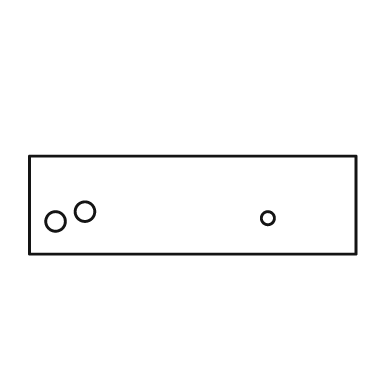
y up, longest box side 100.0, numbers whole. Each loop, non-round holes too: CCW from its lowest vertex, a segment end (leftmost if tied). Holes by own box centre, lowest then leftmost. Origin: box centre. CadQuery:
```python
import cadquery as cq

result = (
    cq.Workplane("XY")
    .moveTo(-50.0, -15.0)
    .lineTo(50.0, -15.0)
    .lineTo(50.0, 15.0)
    .lineTo(-50.0, 15.0)
    .close()
    .moveTo(-42.0, -5.0)
    .circle(3.0)
    .moveTo(23.0, -4.0)
    .circle(2.0)
    .moveTo(-33.0, -2.0)
    .circle(3.0)
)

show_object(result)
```